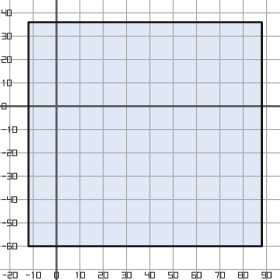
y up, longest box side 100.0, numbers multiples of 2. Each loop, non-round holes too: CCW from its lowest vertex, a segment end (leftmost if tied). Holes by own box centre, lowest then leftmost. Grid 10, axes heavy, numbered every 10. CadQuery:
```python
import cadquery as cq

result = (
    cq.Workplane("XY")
    .moveTo(-12.0, -60.0)
    .lineTo(88.0, -60.0)
    .lineTo(88.0, 36.0)
    .lineTo(-12.0, 36.0)
    .close()
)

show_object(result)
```